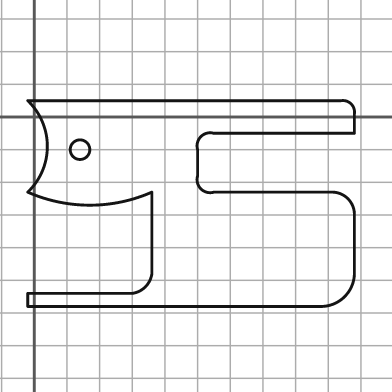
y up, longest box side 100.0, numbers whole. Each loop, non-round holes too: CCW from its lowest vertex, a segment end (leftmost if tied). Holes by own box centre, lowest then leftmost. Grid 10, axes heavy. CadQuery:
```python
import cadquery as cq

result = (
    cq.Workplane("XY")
    .moveTo(-2.0, -58.0)
    .lineTo(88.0, -58.0)
    .threePointArc((95.0, -55.0), (98.0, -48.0))
    .lineTo(98.0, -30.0)
    .threePointArc((96.0, -25.0), (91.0, -23.0))
    .lineTo(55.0, -23.0)
    .threePointArc((51.0, -22.0), (50.0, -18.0))
    .lineTo(50.0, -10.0)
    .threePointArc((51.0, -6.0), (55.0, -5.0))
    .lineTo(98.0, -5.0)
    .lineTo(98.0, 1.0)
    .threePointArc((97.0, 4.0), (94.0, 5.0))
    .lineTo(-2.0, 5.0)
    .threePointArc((4.0, -9.0), (-2.0, -23.0))
    .threePointArc((17.0, -27.0), (36.0, -23.0))
    .lineTo(36.0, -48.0)
    .threePointArc((34.0, -52.0), (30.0, -54.0))
    .lineTo(-2.0, -54.0)
    .close()
    .moveTo(14.0, -10.0)
    .circle(3.0)
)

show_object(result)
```